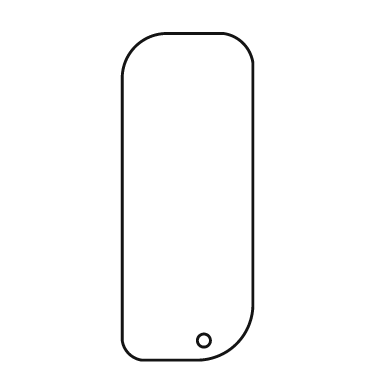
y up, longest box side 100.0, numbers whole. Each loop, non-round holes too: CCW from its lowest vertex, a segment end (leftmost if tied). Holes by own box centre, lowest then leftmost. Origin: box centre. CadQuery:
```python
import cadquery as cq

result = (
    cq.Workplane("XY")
    .moveTo(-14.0, -50.0)
    .lineTo(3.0, -50.0)
    .threePointArc((15.0, -45.0), (20.0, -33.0))
    .lineTo(20.0, 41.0)
    .threePointArc((17.0, 47.0), (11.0, 50.0))
    .lineTo(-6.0, 50.0)
    .threePointArc((-16.0, 46.0), (-20.0, 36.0))
    .lineTo(-20.0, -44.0)
    .threePointArc((-18.0, -48.0), (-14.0, -50.0))
    .close()
    .moveTo(5.0, -44.0)
    .circle(2.0)
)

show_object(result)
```